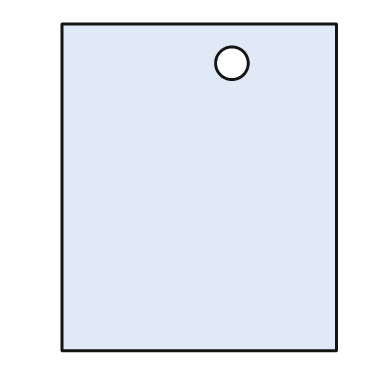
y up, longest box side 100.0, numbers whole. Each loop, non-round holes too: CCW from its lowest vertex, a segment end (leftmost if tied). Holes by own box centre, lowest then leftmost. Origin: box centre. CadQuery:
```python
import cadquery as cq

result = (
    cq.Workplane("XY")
    .moveTo(-42.0, -50.0)
    .lineTo(42.0, -50.0)
    .lineTo(42.0, 50.0)
    .lineTo(-42.0, 50.0)
    .close()
    .moveTo(10.0, 38.0)
    .circle(5.0)
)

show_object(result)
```